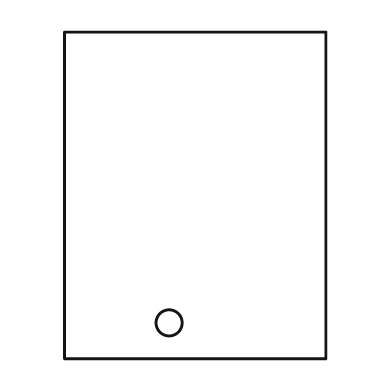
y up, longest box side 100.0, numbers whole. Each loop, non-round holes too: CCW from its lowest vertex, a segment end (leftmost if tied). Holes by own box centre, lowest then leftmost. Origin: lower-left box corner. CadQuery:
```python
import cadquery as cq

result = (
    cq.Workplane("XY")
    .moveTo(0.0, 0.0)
    .lineTo(80.0, 0.0)
    .lineTo(80.0, 100.0)
    .lineTo(0.0, 100.0)
    .close()
    .moveTo(32.0, 11.0)
    .circle(4.0)
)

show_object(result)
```